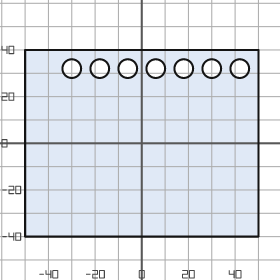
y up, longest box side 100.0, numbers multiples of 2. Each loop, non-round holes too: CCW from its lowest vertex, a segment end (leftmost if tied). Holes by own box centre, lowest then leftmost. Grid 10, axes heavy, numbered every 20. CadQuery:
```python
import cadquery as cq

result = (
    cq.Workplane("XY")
    .moveTo(-50.0, -40.0)
    .lineTo(50.0, -40.0)
    .lineTo(50.0, 40.0)
    .lineTo(-50.0, 40.0)
    .close()
    .moveTo(-30.0, 32.0)
    .circle(4.0)
    .moveTo(-18.0, 32.0)
    .circle(4.0)
    .moveTo(-6.0, 32.0)
    .circle(4.0)
    .moveTo(6.0, 32.0)
    .circle(4.0)
    .moveTo(18.0, 32.0)
    .circle(4.0)
    .moveTo(30.0, 32.0)
    .circle(4.0)
    .moveTo(42.0, 32.0)
    .circle(4.0)
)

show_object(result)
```